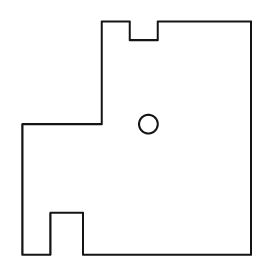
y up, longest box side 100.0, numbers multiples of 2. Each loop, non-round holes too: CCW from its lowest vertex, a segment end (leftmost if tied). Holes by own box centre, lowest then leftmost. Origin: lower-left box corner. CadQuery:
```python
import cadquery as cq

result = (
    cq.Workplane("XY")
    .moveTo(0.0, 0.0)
    .lineTo(12.0, 0.0)
    .lineTo(12.0, 18.0)
    .lineTo(26.0, 18.0)
    .lineTo(26.0, 0.0)
    .lineTo(98.0, 0.0)
    .lineTo(98.0, 100.0)
    .lineTo(58.0, 100.0)
    .lineTo(58.0, 92.0)
    .lineTo(46.0, 92.0)
    .lineTo(46.0, 100.0)
    .lineTo(34.0, 100.0)
    .lineTo(34.0, 56.0)
    .lineTo(0.0, 56.0)
    .close()
    .moveTo(54.0, 56.0)
    .circle(4.0)
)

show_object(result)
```